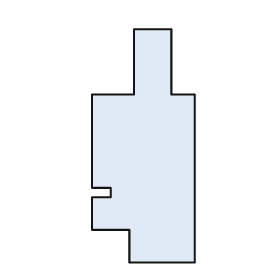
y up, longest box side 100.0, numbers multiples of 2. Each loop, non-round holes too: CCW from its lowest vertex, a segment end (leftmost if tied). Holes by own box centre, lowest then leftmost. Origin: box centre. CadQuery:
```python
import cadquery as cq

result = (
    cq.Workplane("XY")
    .moveTo(-6.0, -50.0)
    .lineTo(22.0, -50.0)
    .lineTo(22.0, 22.0)
    .lineTo(12.0, 22.0)
    .lineTo(12.0, 50.0)
    .lineTo(-4.0, 50.0)
    .lineTo(-4.0, 22.0)
    .lineTo(-22.0, 22.0)
    .lineTo(-22.0, -18.0)
    .lineTo(-14.0, -18.0)
    .lineTo(-14.0, -22.0)
    .lineTo(-22.0, -22.0)
    .lineTo(-22.0, -36.0)
    .lineTo(-6.0, -36.0)
    .close()
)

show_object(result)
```